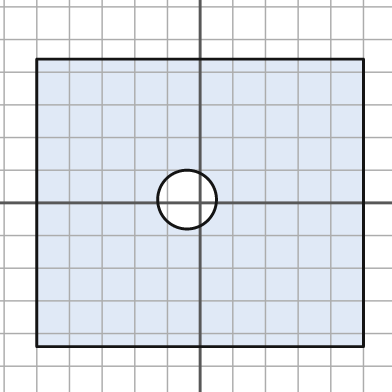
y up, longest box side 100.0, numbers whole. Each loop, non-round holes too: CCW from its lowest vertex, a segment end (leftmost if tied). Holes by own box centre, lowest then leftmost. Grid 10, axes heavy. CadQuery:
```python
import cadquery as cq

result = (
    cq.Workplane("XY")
    .moveTo(-50.0, -44.0)
    .lineTo(50.0, -44.0)
    .lineTo(50.0, 44.0)
    .lineTo(-50.0, 44.0)
    .close()
    .moveTo(-4.0, 1.0)
    .circle(9.0)
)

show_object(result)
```